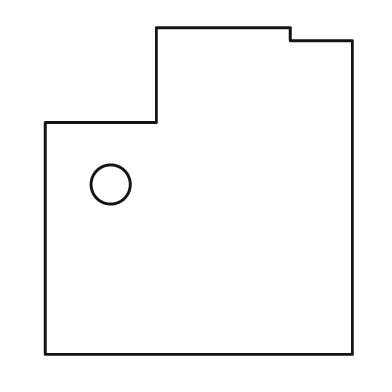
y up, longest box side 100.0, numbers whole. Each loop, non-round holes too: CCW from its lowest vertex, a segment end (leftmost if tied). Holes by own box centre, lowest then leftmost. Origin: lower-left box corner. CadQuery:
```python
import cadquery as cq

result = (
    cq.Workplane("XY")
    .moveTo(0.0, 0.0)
    .lineTo(94.0, 0.0)
    .lineTo(94.0, 96.0)
    .lineTo(75.0, 96.0)
    .lineTo(75.0, 100.0)
    .lineTo(34.0, 100.0)
    .lineTo(34.0, 71.0)
    .lineTo(0.0, 71.0)
    .close()
    .moveTo(20.0, 52.0)
    .circle(6.0)
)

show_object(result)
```